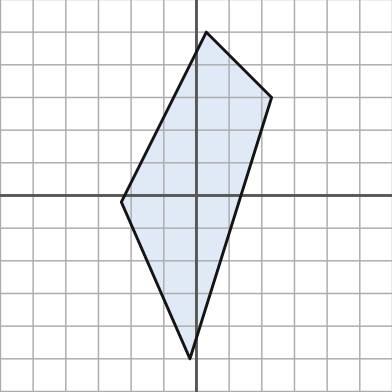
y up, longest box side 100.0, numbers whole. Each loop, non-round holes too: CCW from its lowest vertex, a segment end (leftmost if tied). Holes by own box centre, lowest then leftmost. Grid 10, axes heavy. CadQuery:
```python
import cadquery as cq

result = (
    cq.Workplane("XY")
    .moveTo(-2.0, -50.0)
    .lineTo(23.0, 30.0)
    .lineTo(3.0, 50.0)
    .lineTo(-23.0, -2.0)
    .close()
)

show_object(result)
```